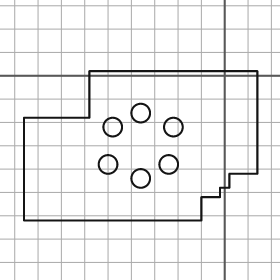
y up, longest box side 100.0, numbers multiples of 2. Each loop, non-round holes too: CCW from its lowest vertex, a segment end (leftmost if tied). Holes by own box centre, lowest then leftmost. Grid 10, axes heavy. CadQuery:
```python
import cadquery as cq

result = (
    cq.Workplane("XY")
    .moveTo(-86.0, -62.0)
    .lineTo(-10.0, -62.0)
    .lineTo(-10.0, -52.0)
    .lineTo(-2.0, -52.0)
    .lineTo(-2.0, -48.0)
    .lineTo(2.0, -48.0)
    .lineTo(2.0, -42.0)
    .lineTo(14.0, -42.0)
    .lineTo(14.0, 2.0)
    .lineTo(-58.0, 2.0)
    .lineTo(-58.0, -18.0)
    .lineTo(-86.0, -18.0)
    .close()
    .moveTo(-36.0, -44.0)
    .circle(4.0)
    .moveTo(-50.0, -38.0)
    .circle(4.0)
    .moveTo(-24.0, -38.0)
    .circle(4.0)
    .moveTo(-48.0, -22.0)
    .circle(4.0)
    .moveTo(-22.0, -22.0)
    .circle(4.0)
    .moveTo(-36.0, -16.0)
    .circle(4.0)
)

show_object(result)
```